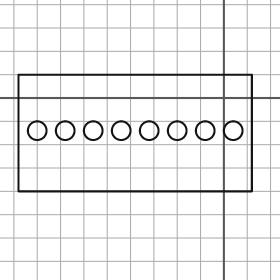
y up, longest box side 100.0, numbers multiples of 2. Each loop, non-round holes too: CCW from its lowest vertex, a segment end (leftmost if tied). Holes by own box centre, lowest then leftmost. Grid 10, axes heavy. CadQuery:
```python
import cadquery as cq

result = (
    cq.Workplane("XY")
    .moveTo(-88.0, -40.0)
    .lineTo(12.0, -40.0)
    .lineTo(12.0, 10.0)
    .lineTo(-88.0, 10.0)
    .close()
    .moveTo(-80.0, -14.0)
    .circle(4.0)
    .moveTo(-68.0, -14.0)
    .circle(4.0)
    .moveTo(-56.0, -14.0)
    .circle(4.0)
    .moveTo(-44.0, -14.0)
    .circle(4.0)
    .moveTo(-32.0, -14.0)
    .circle(4.0)
    .moveTo(-20.0, -14.0)
    .circle(4.0)
    .moveTo(-8.0, -14.0)
    .circle(4.0)
    .moveTo(4.0, -14.0)
    .circle(4.0)
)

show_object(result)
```